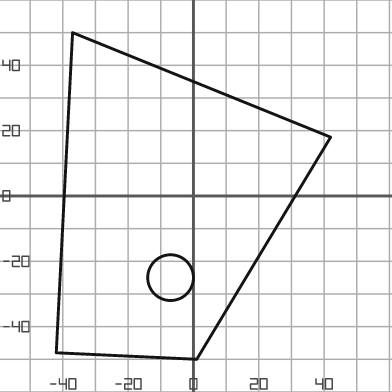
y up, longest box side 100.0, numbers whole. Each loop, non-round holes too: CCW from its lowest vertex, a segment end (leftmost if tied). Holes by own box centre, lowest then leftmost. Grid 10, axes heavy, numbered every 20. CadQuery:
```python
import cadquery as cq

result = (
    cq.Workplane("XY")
    .moveTo(1.0, -50.0)
    .lineTo(42.0, 18.0)
    .lineTo(-37.0, 50.0)
    .lineTo(-42.0, -48.0)
    .close()
    .moveTo(-7.0, -25.0)
    .circle(7.0)
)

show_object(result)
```